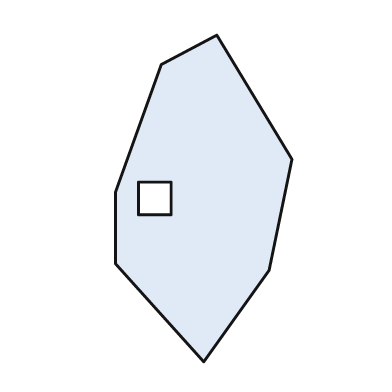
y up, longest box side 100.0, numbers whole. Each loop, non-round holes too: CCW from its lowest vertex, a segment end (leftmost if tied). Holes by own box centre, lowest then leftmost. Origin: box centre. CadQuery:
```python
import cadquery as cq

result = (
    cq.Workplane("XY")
    .moveTo(0.0, -50.0)
    .lineTo(20.0, -22.0)
    .lineTo(27.0, 12.0)
    .lineTo(4.0, 50.0)
    .lineTo(-13.0, 41.0)
    .lineTo(-27.0, 2.0)
    .lineTo(-27.0, -20.0)
    .close()
    .moveTo(-20.0, -5.0)
    .lineTo(-10.0, -5.0)
    .lineTo(-10.0, 5.0)
    .lineTo(-20.0, 5.0)
    .close()
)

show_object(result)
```